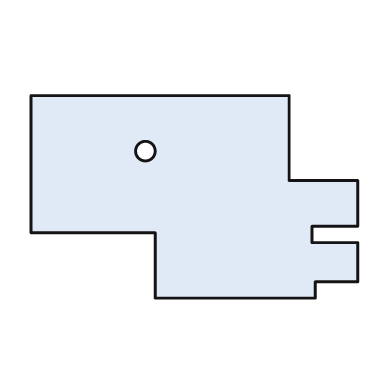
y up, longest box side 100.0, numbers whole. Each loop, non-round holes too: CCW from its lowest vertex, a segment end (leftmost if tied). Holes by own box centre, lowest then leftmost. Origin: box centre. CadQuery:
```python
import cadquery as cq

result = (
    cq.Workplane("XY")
    .moveTo(-12.0, -31.0)
    .lineTo(37.0, -31.0)
    .lineTo(37.0, -26.0)
    .lineTo(50.0, -26.0)
    .lineTo(50.0, -14.0)
    .lineTo(36.0, -14.0)
    .lineTo(36.0, -9.0)
    .lineTo(50.0, -9.0)
    .lineTo(50.0, 5.0)
    .lineTo(29.0, 5.0)
    .lineTo(29.0, 31.0)
    .lineTo(-50.0, 31.0)
    .lineTo(-50.0, -11.0)
    .lineTo(-12.0, -11.0)
    .close()
    .moveTo(-15.0, 14.0)
    .circle(3.0)
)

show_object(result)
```